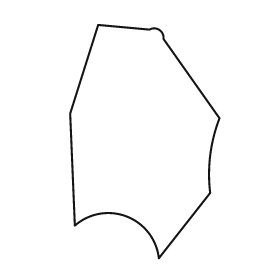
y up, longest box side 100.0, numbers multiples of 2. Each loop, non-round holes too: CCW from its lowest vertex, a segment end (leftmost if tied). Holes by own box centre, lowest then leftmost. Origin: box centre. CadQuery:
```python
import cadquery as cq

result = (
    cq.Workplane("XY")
    .moveTo(6.0, -50.0)
    .lineTo(28.0, -22.0)
    .threePointArc((28.0, -6.0), (32.0, 10.0))
    .lineTo(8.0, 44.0)
    .threePointArc((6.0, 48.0), (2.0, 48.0))
    .lineTo(-20.0, 50.0)
    .lineTo(-32.0, 12.0)
    .lineTo(-30.0, -36.0)
    .threePointArc((-8.0, -32.0), (6.0, -50.0))
    .close()
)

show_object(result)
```